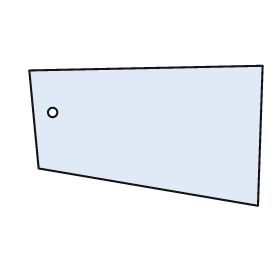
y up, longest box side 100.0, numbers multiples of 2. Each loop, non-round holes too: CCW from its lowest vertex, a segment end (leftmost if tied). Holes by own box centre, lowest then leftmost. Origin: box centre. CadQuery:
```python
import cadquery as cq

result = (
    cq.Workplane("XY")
    .moveTo(48.0, -30.0)
    .lineTo(50.0, 30.0)
    .lineTo(-50.0, 28.0)
    .lineTo(-46.0, -14.0)
    .close()
    .moveTo(-40.0, 10.0)
    .circle(2.0)
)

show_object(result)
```